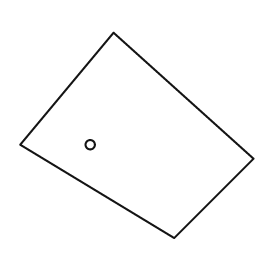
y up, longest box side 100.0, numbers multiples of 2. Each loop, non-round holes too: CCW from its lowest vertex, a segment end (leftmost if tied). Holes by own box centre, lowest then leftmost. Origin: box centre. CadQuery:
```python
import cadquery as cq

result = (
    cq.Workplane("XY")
    .moveTo(16.0, -44.0)
    .lineTo(50.0, -10.0)
    .lineTo(-10.0, 44.0)
    .lineTo(-50.0, -4.0)
    .close()
    .moveTo(-20.0, -4.0)
    .circle(2.0)
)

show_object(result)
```